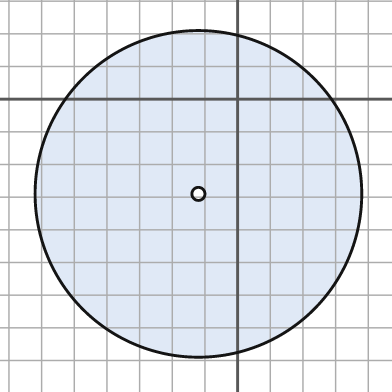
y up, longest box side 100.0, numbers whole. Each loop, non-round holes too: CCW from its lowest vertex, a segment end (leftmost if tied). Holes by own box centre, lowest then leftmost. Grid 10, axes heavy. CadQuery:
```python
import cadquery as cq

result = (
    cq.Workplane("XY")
    .moveTo(-12.0, -29.0)
    .circle(50.0)
    .moveTo(-12.0, -29.0)
    .circle(2.0)
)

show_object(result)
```